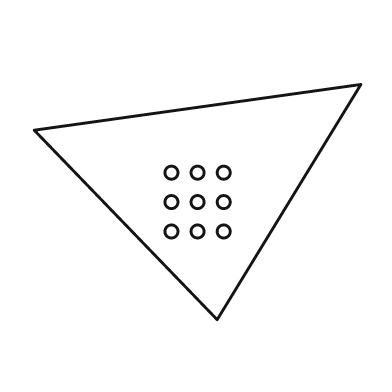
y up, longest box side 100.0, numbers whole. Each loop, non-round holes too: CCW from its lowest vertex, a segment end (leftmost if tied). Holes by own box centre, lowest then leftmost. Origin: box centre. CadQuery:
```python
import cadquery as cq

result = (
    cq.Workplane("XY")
    .moveTo(6.0, -36.0)
    .lineTo(50.0, 36.0)
    .lineTo(-50.0, 22.0)
    .close()
    .moveTo(-8.0, -9.0)
    .circle(2.0)
    .moveTo(0.0, -9.0)
    .circle(2.0)
    .moveTo(8.0, -9.0)
    .circle(2.0)
    .moveTo(-8.0, 0.0)
    .circle(2.0)
    .moveTo(0.0, 0.0)
    .circle(2.0)
    .moveTo(8.0, 0.0)
    .circle(2.0)
    .moveTo(-8.0, 9.0)
    .circle(2.0)
    .moveTo(0.0, 9.0)
    .circle(2.0)
    .moveTo(8.0, 9.0)
    .circle(2.0)
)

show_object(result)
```